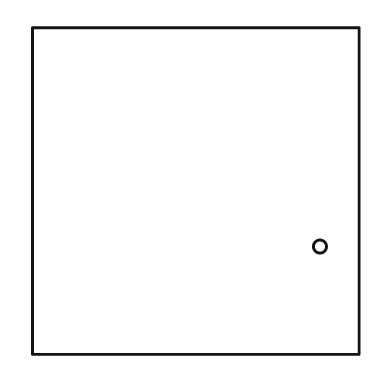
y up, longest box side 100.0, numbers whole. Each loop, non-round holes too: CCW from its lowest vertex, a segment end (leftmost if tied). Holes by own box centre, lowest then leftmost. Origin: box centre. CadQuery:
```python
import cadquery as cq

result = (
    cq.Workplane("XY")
    .moveTo(-50.0, -50.0)
    .lineTo(50.0, -50.0)
    .lineTo(50.0, 50.0)
    .lineTo(-50.0, 50.0)
    .close()
    .moveTo(38.0, -17.0)
    .circle(2.0)
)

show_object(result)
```